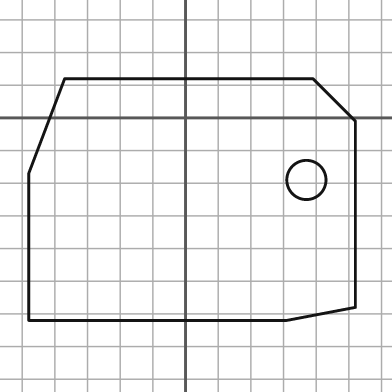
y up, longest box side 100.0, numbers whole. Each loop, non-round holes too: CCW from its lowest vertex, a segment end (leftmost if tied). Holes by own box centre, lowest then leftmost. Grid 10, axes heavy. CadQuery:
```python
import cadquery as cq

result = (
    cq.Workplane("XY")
    .moveTo(-48.0, -62.0)
    .lineTo(31.0, -62.0)
    .lineTo(52.0, -58.0)
    .lineTo(52.0, -1.0)
    .lineTo(39.0, 12.0)
    .lineTo(-37.0, 12.0)
    .lineTo(-48.0, -17.0)
    .close()
    .moveTo(37.0, -19.0)
    .circle(6.0)
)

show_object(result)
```